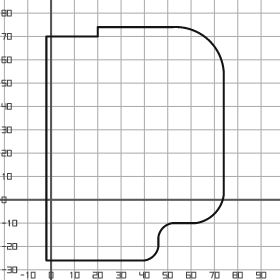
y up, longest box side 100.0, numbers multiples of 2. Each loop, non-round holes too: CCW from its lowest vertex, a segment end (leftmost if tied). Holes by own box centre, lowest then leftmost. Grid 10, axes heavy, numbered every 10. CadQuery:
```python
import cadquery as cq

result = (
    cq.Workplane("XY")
    .moveTo(-2.0, -26.0)
    .lineTo(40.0, -26.0)
    .threePointArc((44.0, -24.0), (46.0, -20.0))
    .lineTo(46.0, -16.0)
    .threePointArc((48.0, -12.0), (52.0, -10.0))
    .lineTo(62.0, -10.0)
    .threePointArc((70.0, -6.0), (74.0, 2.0))
    .lineTo(74.0, 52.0)
    .threePointArc((68.0, 68.0), (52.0, 74.0))
    .lineTo(20.0, 74.0)
    .lineTo(20.0, 70.0)
    .lineTo(-2.0, 70.0)
    .close()
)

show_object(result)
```